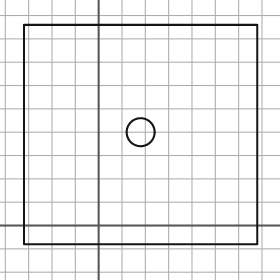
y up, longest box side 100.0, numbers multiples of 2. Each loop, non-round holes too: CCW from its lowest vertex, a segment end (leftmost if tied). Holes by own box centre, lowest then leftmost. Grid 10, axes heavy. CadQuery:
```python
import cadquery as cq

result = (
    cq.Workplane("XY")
    .moveTo(-32.0, -8.0)
    .lineTo(68.0, -8.0)
    .lineTo(68.0, 86.0)
    .lineTo(-32.0, 86.0)
    .close()
    .moveTo(18.0, 40.0)
    .circle(6.0)
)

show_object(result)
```